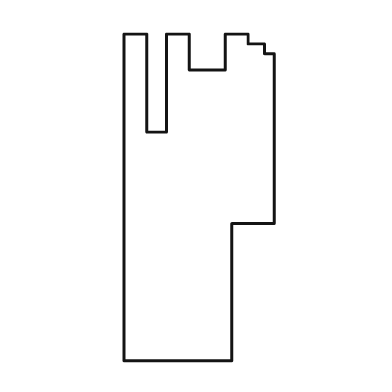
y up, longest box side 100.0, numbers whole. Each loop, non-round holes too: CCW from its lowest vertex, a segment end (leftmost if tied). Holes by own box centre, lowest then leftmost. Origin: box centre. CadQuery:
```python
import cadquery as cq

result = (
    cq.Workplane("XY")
    .moveTo(-23.0, -50.0)
    .lineTo(10.0, -50.0)
    .lineTo(10.0, -8.0)
    .lineTo(23.0, -8.0)
    .lineTo(23.0, 44.0)
    .lineTo(20.0, 44.0)
    .lineTo(20.0, 47.0)
    .lineTo(15.0, 47.0)
    .lineTo(15.0, 50.0)
    .lineTo(8.0, 50.0)
    .lineTo(8.0, 39.0)
    .lineTo(-3.0, 39.0)
    .lineTo(-3.0, 50.0)
    .lineTo(-10.0, 50.0)
    .lineTo(-10.0, 20.0)
    .lineTo(-16.0, 20.0)
    .lineTo(-16.0, 50.0)
    .lineTo(-23.0, 50.0)
    .close()
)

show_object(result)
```